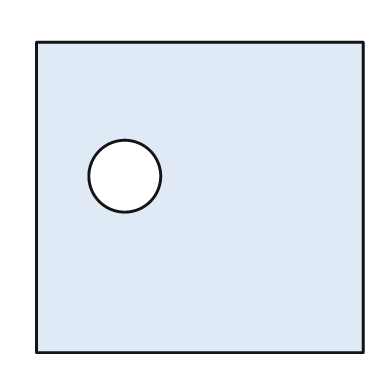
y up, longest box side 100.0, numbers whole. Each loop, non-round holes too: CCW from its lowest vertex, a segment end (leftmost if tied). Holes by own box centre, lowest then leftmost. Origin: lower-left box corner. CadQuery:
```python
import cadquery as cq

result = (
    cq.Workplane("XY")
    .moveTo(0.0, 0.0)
    .lineTo(100.0, 0.0)
    .lineTo(100.0, 95.0)
    .lineTo(0.0, 95.0)
    .close()
    .moveTo(27.0, 54.0)
    .circle(11.0)
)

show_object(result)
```